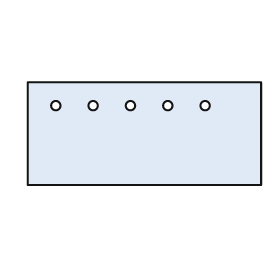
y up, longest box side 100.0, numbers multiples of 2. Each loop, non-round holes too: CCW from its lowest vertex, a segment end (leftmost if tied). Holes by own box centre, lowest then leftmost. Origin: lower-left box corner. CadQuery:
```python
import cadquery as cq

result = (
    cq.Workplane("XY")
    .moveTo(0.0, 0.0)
    .lineTo(100.0, 0.0)
    .lineTo(100.0, 44.0)
    .lineTo(0.0, 44.0)
    .close()
    .moveTo(12.0, 34.0)
    .circle(2.0)
    .moveTo(28.0, 34.0)
    .circle(2.0)
    .moveTo(44.0, 34.0)
    .circle(2.0)
    .moveTo(60.0, 34.0)
    .circle(2.0)
    .moveTo(76.0, 34.0)
    .circle(2.0)
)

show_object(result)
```